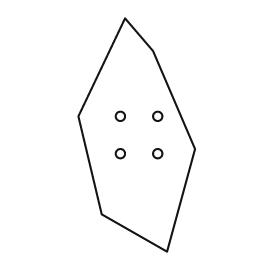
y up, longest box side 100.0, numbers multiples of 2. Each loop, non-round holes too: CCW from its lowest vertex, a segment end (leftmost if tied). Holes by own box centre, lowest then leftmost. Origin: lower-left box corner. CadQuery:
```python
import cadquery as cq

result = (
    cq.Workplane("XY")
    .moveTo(38.0, 0.0)
    .lineTo(50.0, 44.0)
    .lineTo(32.0, 86.0)
    .lineTo(20.0, 100.0)
    .lineTo(0.0, 58.0)
    .lineTo(10.0, 16.0)
    .close()
    .moveTo(18.0, 42.0)
    .circle(2.0)
    .moveTo(34.0, 42.0)
    .circle(2.0)
    .moveTo(18.0, 58.0)
    .circle(2.0)
    .moveTo(34.0, 58.0)
    .circle(2.0)
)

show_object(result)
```